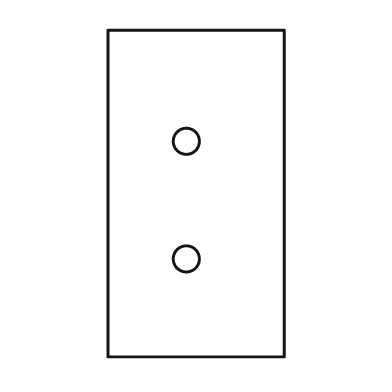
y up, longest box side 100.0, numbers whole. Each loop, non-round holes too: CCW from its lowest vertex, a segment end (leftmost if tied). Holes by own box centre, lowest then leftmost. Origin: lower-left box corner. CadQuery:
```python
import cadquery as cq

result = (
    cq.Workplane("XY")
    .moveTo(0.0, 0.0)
    .lineTo(54.0, 0.0)
    .lineTo(54.0, 100.0)
    .lineTo(0.0, 100.0)
    .close()
    .moveTo(24.0, 30.0)
    .circle(4.0)
    .moveTo(24.0, 66.0)
    .circle(4.0)
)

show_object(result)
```